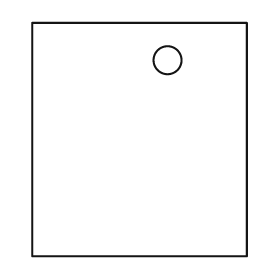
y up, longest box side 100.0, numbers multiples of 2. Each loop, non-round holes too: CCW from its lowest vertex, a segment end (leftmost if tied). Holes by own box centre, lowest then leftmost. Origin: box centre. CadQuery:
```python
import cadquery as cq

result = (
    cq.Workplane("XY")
    .moveTo(-46.0, -50.0)
    .lineTo(46.0, -50.0)
    .lineTo(46.0, 50.0)
    .lineTo(-46.0, 50.0)
    .close()
    .moveTo(12.0, 34.0)
    .circle(6.0)
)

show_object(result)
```